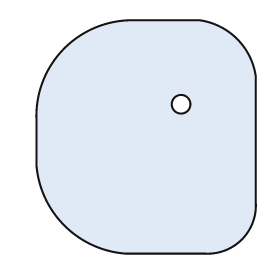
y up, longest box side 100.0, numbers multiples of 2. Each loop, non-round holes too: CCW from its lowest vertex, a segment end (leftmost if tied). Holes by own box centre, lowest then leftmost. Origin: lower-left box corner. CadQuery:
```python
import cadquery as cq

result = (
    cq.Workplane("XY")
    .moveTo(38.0, 0.0)
    .lineTo(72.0, 0.0)
    .threePointArc((88.0, 6.0), (94.0, 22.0))
    .lineTo(94.0, 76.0)
    .threePointArc((86.0, 92.0), (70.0, 100.0))
    .lineTo(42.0, 100.0)
    .threePointArc((12.0, 88.0), (0.0, 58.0))
    .lineTo(0.0, 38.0)
    .threePointArc((12.0, 12.0), (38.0, 0.0))
    .close()
    .moveTo(62.0, 64.0)
    .circle(4.0)
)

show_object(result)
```